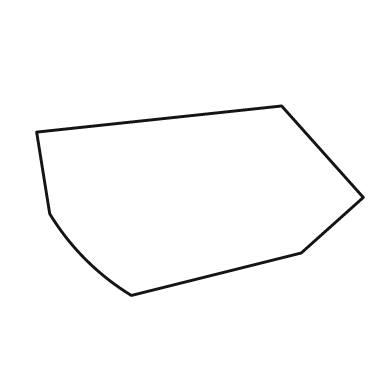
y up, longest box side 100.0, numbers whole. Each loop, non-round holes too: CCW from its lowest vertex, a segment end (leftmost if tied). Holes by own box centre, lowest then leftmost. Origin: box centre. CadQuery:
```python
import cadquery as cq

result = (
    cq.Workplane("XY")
    .moveTo(-21.0, -29.0)
    .lineTo(31.0, -16.0)
    .lineTo(50.0, 1.0)
    .lineTo(25.0, 29.0)
    .lineTo(-50.0, 21.0)
    .lineTo(-46.0, -4.0)
    .threePointArc((-35.0, -18.0), (-21.0, -29.0))
    .close()
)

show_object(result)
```